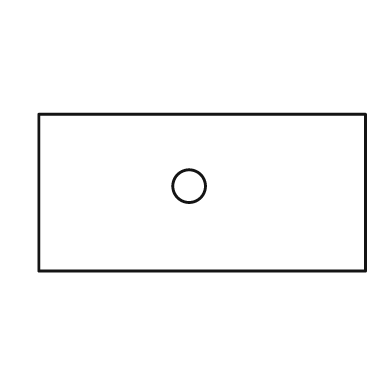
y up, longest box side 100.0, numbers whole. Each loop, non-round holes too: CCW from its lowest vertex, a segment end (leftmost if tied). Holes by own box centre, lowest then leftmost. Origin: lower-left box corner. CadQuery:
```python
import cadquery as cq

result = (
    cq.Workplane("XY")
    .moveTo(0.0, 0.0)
    .lineTo(100.0, 0.0)
    .lineTo(100.0, 48.0)
    .lineTo(0.0, 48.0)
    .close()
    .moveTo(46.0, 26.0)
    .circle(5.0)
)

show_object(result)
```